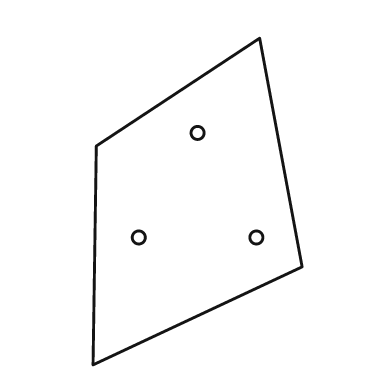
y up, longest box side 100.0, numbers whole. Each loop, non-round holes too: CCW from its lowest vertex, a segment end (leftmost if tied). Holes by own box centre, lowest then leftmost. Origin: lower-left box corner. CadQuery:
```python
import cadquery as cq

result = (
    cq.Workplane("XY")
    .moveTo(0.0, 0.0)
    .lineTo(64.0, 30.0)
    .lineTo(51.0, 100.0)
    .lineTo(1.0, 67.0)
    .close()
    .moveTo(14.0, 39.0)
    .circle(2.0)
    .moveTo(50.0, 39.0)
    .circle(2.0)
    .moveTo(32.0, 71.0)
    .circle(2.0)
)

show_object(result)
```